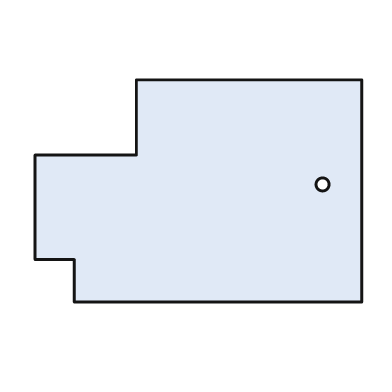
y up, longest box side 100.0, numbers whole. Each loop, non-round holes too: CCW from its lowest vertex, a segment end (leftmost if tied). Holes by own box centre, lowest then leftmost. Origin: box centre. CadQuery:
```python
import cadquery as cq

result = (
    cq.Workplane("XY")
    .moveTo(-38.0, -34.0)
    .lineTo(50.0, -34.0)
    .lineTo(50.0, 34.0)
    .lineTo(-19.0, 34.0)
    .lineTo(-19.0, 11.0)
    .lineTo(-50.0, 11.0)
    .lineTo(-50.0, -21.0)
    .lineTo(-38.0, -21.0)
    .close()
    .moveTo(38.0, 2.0)
    .circle(2.0)
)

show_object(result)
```